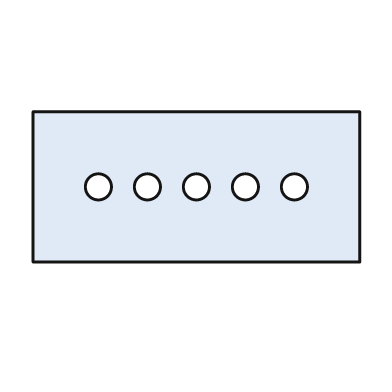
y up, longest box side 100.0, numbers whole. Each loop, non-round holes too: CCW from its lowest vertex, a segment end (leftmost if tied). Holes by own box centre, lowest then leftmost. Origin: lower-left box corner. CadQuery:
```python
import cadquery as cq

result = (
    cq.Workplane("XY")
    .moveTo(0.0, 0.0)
    .lineTo(100.0, 0.0)
    .lineTo(100.0, 46.0)
    .lineTo(0.0, 46.0)
    .close()
    .moveTo(20.0, 23.0)
    .circle(4.0)
    .moveTo(35.0, 23.0)
    .circle(4.0)
    .moveTo(50.0, 23.0)
    .circle(4.0)
    .moveTo(65.0, 23.0)
    .circle(4.0)
    .moveTo(80.0, 23.0)
    .circle(4.0)
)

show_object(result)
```